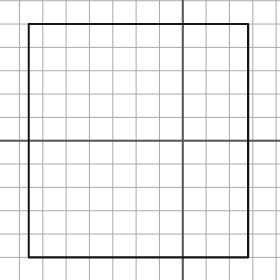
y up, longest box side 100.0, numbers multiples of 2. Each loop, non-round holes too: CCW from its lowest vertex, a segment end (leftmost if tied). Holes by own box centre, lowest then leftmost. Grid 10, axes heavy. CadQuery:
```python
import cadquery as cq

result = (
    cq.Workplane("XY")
    .moveTo(-66.0, -50.0)
    .lineTo(28.0, -50.0)
    .lineTo(28.0, 50.0)
    .lineTo(-66.0, 50.0)
    .close()
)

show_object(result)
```